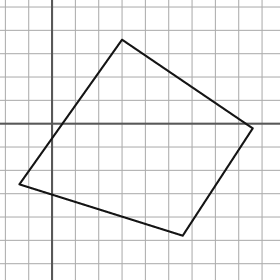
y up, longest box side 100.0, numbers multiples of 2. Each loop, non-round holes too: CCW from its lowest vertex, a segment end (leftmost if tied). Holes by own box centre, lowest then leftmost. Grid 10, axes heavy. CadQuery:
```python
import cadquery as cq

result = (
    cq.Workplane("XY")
    .moveTo(56.0, -48.0)
    .lineTo(86.0, -2.0)
    .lineTo(30.0, 36.0)
    .lineTo(-14.0, -26.0)
    .close()
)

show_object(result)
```